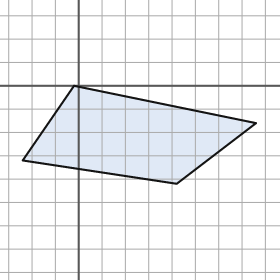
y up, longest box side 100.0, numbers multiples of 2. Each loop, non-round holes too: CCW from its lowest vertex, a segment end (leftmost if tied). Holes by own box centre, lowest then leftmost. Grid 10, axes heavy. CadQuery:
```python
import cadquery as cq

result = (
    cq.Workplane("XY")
    .moveTo(42.0, -42.0)
    .lineTo(76.0, -16.0)
    .lineTo(-2.0, 0.0)
    .lineTo(-24.0, -32.0)
    .close()
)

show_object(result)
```